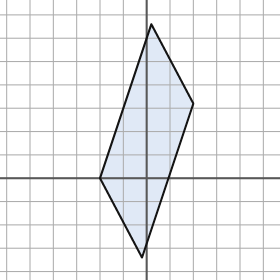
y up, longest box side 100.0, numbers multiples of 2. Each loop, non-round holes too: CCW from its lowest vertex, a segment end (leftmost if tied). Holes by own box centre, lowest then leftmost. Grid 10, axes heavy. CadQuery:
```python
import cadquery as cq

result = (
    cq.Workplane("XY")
    .moveTo(-2.0, -34.0)
    .lineTo(20.0, 32.0)
    .lineTo(2.0, 66.0)
    .lineTo(-20.0, 0.0)
    .close()
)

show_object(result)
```